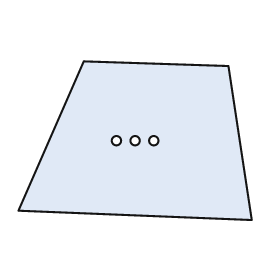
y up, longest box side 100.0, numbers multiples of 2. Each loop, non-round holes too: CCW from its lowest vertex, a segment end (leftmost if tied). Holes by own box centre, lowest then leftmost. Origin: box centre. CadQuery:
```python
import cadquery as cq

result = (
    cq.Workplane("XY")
    .moveTo(50.0, -34.0)
    .lineTo(40.0, 32.0)
    .lineTo(-22.0, 34.0)
    .lineTo(-50.0, -30.0)
    .close()
    .moveTo(-8.0, 0.0)
    .circle(2.0)
    .moveTo(0.0, 0.0)
    .circle(2.0)
    .moveTo(8.0, 0.0)
    .circle(2.0)
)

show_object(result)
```